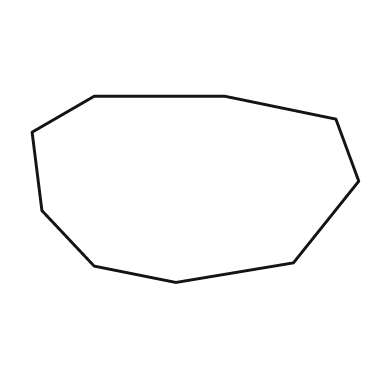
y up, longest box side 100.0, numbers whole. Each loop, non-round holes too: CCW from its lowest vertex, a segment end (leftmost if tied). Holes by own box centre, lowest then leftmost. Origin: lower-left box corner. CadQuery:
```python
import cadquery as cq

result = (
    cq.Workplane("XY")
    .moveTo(44.0, 0.0)
    .lineTo(80.0, 6.0)
    .lineTo(100.0, 31.0)
    .lineTo(93.0, 50.0)
    .lineTo(59.0, 57.0)
    .lineTo(19.0, 57.0)
    .lineTo(0.0, 46.0)
    .lineTo(3.0, 22.0)
    .lineTo(19.0, 5.0)
    .close()
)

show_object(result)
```